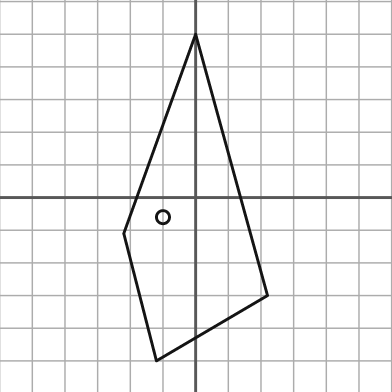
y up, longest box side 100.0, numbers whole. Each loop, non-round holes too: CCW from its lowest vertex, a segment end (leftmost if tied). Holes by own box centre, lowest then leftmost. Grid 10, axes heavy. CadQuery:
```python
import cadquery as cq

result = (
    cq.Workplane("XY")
    .moveTo(-12.0, -50.0)
    .lineTo(22.0, -30.0)
    .lineTo(0.0, 50.0)
    .lineTo(-22.0, -11.0)
    .close()
    .moveTo(-10.0, -6.0)
    .circle(2.0)
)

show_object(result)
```